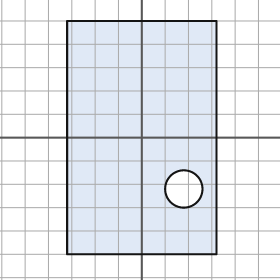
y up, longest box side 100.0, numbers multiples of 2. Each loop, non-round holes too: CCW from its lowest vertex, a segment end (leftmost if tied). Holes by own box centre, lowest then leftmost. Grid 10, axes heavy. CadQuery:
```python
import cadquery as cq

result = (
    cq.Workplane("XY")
    .moveTo(-32.0, -50.0)
    .lineTo(32.0, -50.0)
    .lineTo(32.0, 50.0)
    .lineTo(-32.0, 50.0)
    .close()
    .moveTo(18.0, -22.0)
    .circle(8.0)
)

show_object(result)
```